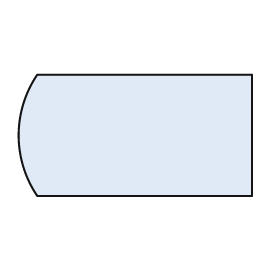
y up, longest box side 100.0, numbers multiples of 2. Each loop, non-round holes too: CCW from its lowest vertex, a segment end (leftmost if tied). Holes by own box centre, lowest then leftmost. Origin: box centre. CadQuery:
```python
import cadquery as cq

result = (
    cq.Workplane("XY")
    .moveTo(-42.0, -26.0)
    .lineTo(50.0, -26.0)
    .lineTo(50.0, 26.0)
    .lineTo(-42.0, 26.0)
    .threePointArc((-50.0, 0.0), (-42.0, -26.0))
    .close()
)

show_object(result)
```